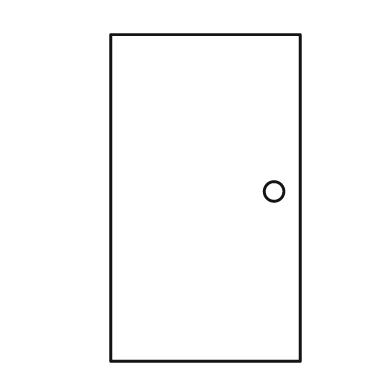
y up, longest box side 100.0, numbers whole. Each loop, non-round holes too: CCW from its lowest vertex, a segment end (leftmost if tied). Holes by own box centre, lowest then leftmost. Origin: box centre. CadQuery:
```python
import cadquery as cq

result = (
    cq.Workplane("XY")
    .moveTo(-29.0, -50.0)
    .lineTo(29.0, -50.0)
    .lineTo(29.0, 50.0)
    .lineTo(-29.0, 50.0)
    .close()
    .moveTo(21.0, 2.0)
    .circle(3.0)
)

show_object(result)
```